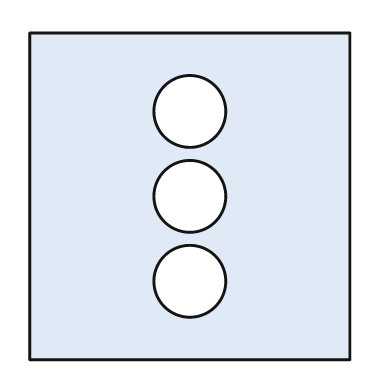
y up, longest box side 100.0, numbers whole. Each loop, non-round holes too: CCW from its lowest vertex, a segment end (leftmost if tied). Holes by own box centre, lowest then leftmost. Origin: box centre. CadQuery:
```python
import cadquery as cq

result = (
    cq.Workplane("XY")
    .moveTo(-49.0, -50.0)
    .lineTo(49.0, -50.0)
    .lineTo(49.0, 50.0)
    .lineTo(-49.0, 50.0)
    .close()
    .moveTo(0.0, -26.0)
    .circle(11.0)
    .moveTo(0.0, 0.0)
    .circle(11.0)
    .moveTo(0.0, 26.0)
    .circle(11.0)
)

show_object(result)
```